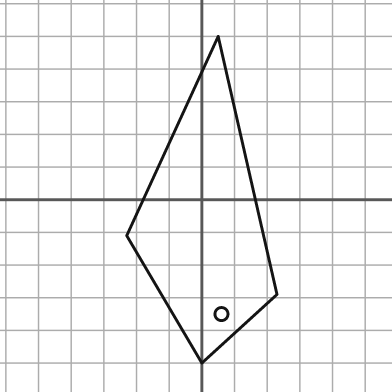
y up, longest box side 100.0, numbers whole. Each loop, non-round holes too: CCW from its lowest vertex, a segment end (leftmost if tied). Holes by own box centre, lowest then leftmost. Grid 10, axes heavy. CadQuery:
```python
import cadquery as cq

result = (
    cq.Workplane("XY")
    .moveTo(0.0, -50.0)
    .lineTo(23.0, -29.0)
    .lineTo(5.0, 50.0)
    .lineTo(-23.0, -11.0)
    .close()
    .moveTo(6.0, -35.0)
    .circle(2.0)
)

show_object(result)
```